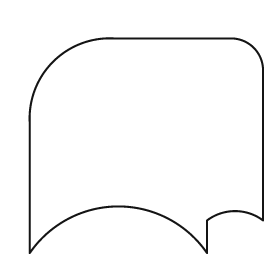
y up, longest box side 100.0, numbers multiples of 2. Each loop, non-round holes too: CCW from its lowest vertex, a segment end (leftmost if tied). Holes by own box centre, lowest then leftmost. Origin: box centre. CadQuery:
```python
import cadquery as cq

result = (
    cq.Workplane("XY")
    .moveTo(-50.0, -46.0)
    .threePointArc((-12.0, -26.0), (26.0, -46.0))
    .lineTo(26.0, -32.0)
    .threePointArc((38.0, -28.0), (50.0, -32.0))
    .lineTo(50.0, 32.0)
    .threePointArc((46.0, 42.0), (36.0, 46.0))
    .lineTo(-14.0, 46.0)
    .threePointArc((-40.0, 36.0), (-50.0, 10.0))
    .close()
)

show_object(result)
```